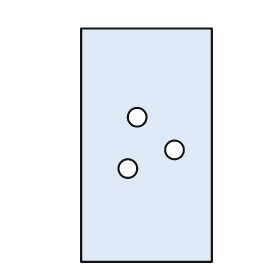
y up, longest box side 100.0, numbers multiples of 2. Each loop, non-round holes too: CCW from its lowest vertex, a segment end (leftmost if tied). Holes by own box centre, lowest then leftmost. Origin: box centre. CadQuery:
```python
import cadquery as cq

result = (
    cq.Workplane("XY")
    .moveTo(-28.0, -50.0)
    .lineTo(28.0, -50.0)
    .lineTo(28.0, 50.0)
    .lineTo(-28.0, 50.0)
    .close()
    .moveTo(-8.0, -10.0)
    .circle(4.0)
    .moveTo(12.0, -2.0)
    .circle(4.0)
    .moveTo(-4.0, 12.0)
    .circle(4.0)
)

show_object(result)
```